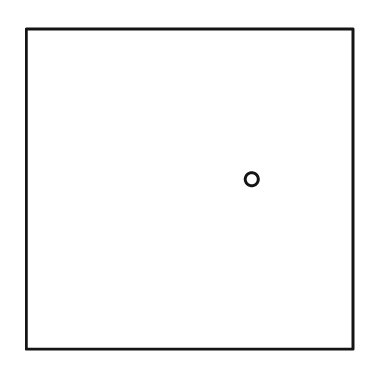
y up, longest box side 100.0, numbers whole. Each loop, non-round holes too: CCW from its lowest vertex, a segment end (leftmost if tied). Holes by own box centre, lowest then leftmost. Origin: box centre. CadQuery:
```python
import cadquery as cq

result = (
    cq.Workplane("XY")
    .moveTo(-50.0, -49.0)
    .lineTo(50.0, -49.0)
    .lineTo(50.0, 49.0)
    .lineTo(-50.0, 49.0)
    .close()
    .moveTo(19.0, 3.0)
    .circle(2.0)
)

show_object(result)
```